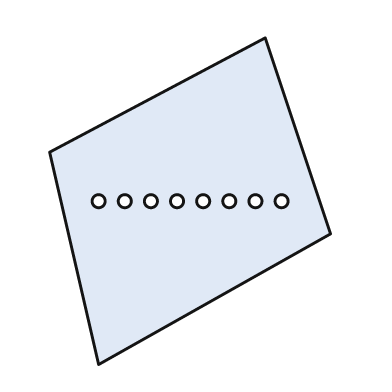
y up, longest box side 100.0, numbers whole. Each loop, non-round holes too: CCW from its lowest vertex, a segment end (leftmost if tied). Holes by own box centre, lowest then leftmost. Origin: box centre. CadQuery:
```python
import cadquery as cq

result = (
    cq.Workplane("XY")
    .moveTo(-28.0, -50.0)
    .lineTo(43.0, -10.0)
    .lineTo(23.0, 50.0)
    .lineTo(-43.0, 15.0)
    .close()
    .moveTo(-28.0, 0.0)
    .circle(2.0)
    .moveTo(-20.0, 0.0)
    .circle(2.0)
    .moveTo(-12.0, 0.0)
    .circle(2.0)
    .moveTo(-4.0, 0.0)
    .circle(2.0)
    .moveTo(4.0, 0.0)
    .circle(2.0)
    .moveTo(12.0, 0.0)
    .circle(2.0)
    .moveTo(20.0, 0.0)
    .circle(2.0)
    .moveTo(28.0, 0.0)
    .circle(2.0)
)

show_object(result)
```